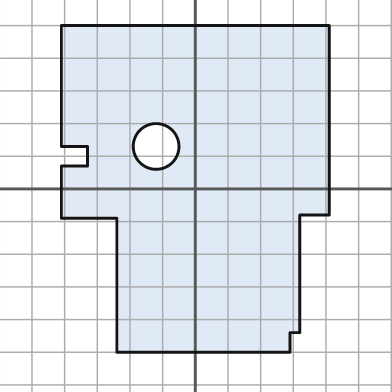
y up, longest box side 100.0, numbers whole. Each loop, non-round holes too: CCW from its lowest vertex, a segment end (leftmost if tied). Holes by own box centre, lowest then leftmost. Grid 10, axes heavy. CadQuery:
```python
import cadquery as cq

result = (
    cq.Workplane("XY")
    .moveTo(-24.0, -50.0)
    .lineTo(29.0, -50.0)
    .lineTo(29.0, -44.0)
    .lineTo(32.0, -44.0)
    .lineTo(32.0, -8.0)
    .lineTo(41.0, -8.0)
    .lineTo(41.0, 50.0)
    .lineTo(-41.0, 50.0)
    .lineTo(-41.0, 13.0)
    .lineTo(-33.0, 13.0)
    .lineTo(-33.0, 7.0)
    .lineTo(-41.0, 7.0)
    .lineTo(-41.0, -9.0)
    .lineTo(-24.0, -9.0)
    .close()
    .moveTo(-12.0, 13.0)
    .circle(7.0)
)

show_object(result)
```